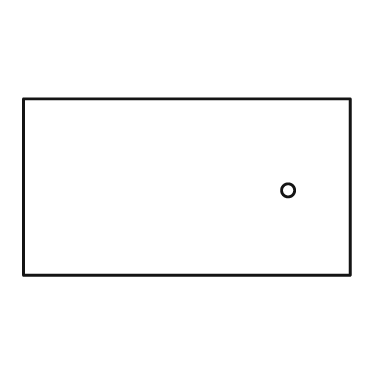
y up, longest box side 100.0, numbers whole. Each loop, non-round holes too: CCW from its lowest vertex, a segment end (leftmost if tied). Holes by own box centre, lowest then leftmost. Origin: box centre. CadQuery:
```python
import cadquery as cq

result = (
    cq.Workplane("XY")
    .moveTo(-50.0, -27.0)
    .lineTo(50.0, -27.0)
    .lineTo(50.0, 27.0)
    .lineTo(-50.0, 27.0)
    .close()
    .moveTo(31.0, -1.0)
    .circle(2.0)
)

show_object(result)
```